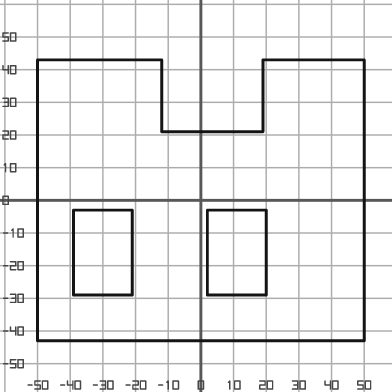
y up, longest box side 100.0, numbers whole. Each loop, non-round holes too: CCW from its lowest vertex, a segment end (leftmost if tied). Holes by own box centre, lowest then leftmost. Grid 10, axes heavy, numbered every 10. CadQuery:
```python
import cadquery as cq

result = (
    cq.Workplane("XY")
    .moveTo(-50.0, -43.0)
    .lineTo(50.0, -43.0)
    .lineTo(50.0, 43.0)
    .lineTo(19.0, 43.0)
    .lineTo(19.0, 21.0)
    .lineTo(-12.0, 21.0)
    .lineTo(-12.0, 43.0)
    .lineTo(-50.0, 43.0)
    .close()
    .moveTo(-39.0, -29.0)
    .lineTo(-21.0, -29.0)
    .lineTo(-21.0, -3.0)
    .lineTo(-39.0, -3.0)
    .close()
    .moveTo(2.0, -29.0)
    .lineTo(20.0, -29.0)
    .lineTo(20.0, -3.0)
    .lineTo(2.0, -3.0)
    .close()
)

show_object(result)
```